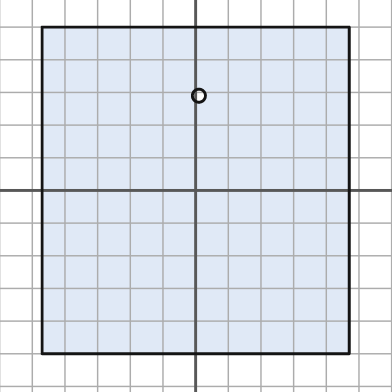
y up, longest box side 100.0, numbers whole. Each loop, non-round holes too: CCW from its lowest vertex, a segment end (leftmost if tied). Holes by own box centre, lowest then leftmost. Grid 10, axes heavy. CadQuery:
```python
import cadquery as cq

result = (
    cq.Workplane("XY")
    .moveTo(-47.0, -50.0)
    .lineTo(47.0, -50.0)
    .lineTo(47.0, 50.0)
    .lineTo(-47.0, 50.0)
    .close()
    .moveTo(1.0, 29.0)
    .circle(2.0)
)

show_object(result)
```